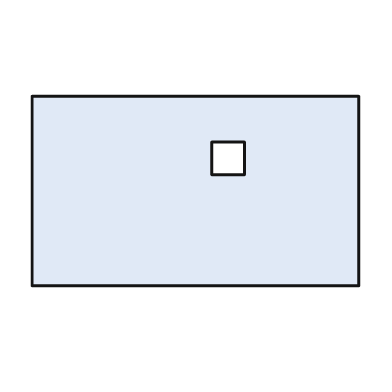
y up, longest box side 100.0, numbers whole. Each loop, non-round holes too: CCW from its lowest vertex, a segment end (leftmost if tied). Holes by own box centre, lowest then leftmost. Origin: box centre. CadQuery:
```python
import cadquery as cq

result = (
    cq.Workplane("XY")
    .moveTo(-50.0, -29.0)
    .lineTo(50.0, -29.0)
    .lineTo(50.0, 29.0)
    .lineTo(-50.0, 29.0)
    .close()
    .moveTo(5.0, 5.0)
    .lineTo(15.0, 5.0)
    .lineTo(15.0, 15.0)
    .lineTo(5.0, 15.0)
    .close()
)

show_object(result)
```